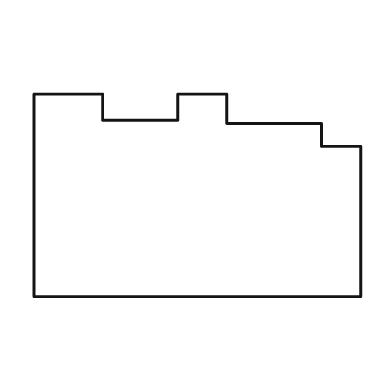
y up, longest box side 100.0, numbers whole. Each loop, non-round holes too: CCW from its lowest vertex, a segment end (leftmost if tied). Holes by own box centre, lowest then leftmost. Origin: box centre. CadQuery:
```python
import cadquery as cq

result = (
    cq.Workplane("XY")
    .moveTo(-50.0, -31.0)
    .lineTo(50.0, -31.0)
    .lineTo(50.0, 15.0)
    .lineTo(38.0, 15.0)
    .lineTo(38.0, 22.0)
    .lineTo(9.0, 22.0)
    .lineTo(9.0, 31.0)
    .lineTo(-6.0, 31.0)
    .lineTo(-6.0, 23.0)
    .lineTo(-29.0, 23.0)
    .lineTo(-29.0, 31.0)
    .lineTo(-50.0, 31.0)
    .close()
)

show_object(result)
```